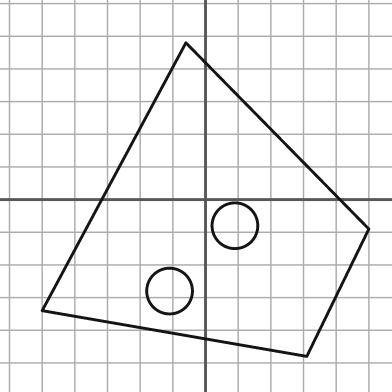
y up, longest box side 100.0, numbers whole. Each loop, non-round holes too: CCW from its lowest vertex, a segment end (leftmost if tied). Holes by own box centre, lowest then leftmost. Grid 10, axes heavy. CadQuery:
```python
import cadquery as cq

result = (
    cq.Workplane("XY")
    .moveTo(31.0, -48.0)
    .lineTo(50.0, -9.0)
    .lineTo(-6.0, 48.0)
    .lineTo(-50.0, -34.0)
    .close()
    .moveTo(-11.0, -28.0)
    .circle(7.0)
    .moveTo(9.0, -8.0)
    .circle(7.0)
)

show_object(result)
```